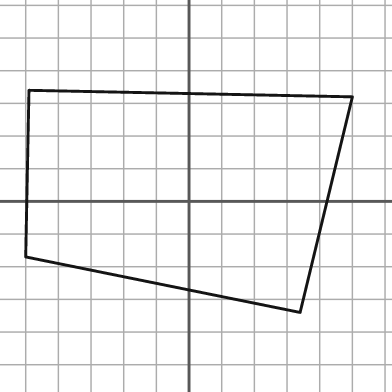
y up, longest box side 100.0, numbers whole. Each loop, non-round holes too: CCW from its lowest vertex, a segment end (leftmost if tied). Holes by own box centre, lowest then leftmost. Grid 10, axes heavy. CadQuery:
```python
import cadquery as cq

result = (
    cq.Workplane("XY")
    .moveTo(34.0, -34.0)
    .lineTo(50.0, 32.0)
    .lineTo(-49.0, 34.0)
    .lineTo(-50.0, -17.0)
    .close()
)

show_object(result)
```